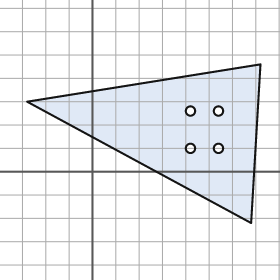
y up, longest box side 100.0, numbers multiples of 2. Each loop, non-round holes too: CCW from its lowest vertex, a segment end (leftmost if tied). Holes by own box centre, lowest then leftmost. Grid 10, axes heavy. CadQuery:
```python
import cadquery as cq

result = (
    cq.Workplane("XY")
    .moveTo(68.0, -22.0)
    .lineTo(72.0, 46.0)
    .lineTo(-28.0, 30.0)
    .close()
    .moveTo(42.0, 10.0)
    .circle(2.0)
    .moveTo(54.0, 10.0)
    .circle(2.0)
    .moveTo(42.0, 26.0)
    .circle(2.0)
    .moveTo(54.0, 26.0)
    .circle(2.0)
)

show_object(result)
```